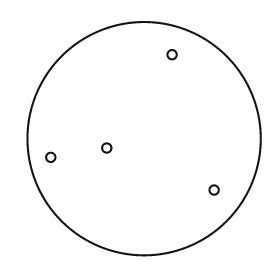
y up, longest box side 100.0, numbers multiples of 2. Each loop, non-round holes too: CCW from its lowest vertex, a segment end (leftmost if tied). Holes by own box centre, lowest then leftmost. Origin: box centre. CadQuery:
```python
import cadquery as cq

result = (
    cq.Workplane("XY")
    .moveTo(0.0, 0.0)
    .circle(50.0)
    .moveTo(30.0, -22.0)
    .circle(2.0)
    .moveTo(-40.0, -8.0)
    .circle(2.0)
    .moveTo(-16.0, -4.0)
    .circle(2.0)
    .moveTo(12.0, 36.0)
    .circle(2.0)
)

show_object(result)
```